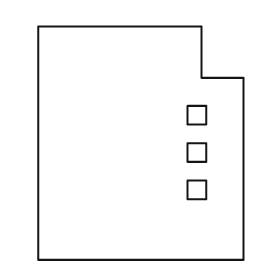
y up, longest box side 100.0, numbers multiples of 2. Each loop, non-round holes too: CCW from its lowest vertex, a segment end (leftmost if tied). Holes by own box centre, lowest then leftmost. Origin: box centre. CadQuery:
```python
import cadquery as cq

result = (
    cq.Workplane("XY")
    .moveTo(-44.0, -50.0)
    .lineTo(44.0, -50.0)
    .lineTo(44.0, 28.0)
    .lineTo(26.0, 28.0)
    .lineTo(26.0, 50.0)
    .lineTo(-44.0, 50.0)
    .close()
    .moveTo(20.0, -24.0)
    .lineTo(28.0, -24.0)
    .lineTo(28.0, -16.0)
    .lineTo(20.0, -16.0)
    .close()
    .moveTo(20.0, -8.0)
    .lineTo(28.0, -8.0)
    .lineTo(28.0, 0.0)
    .lineTo(20.0, 0.0)
    .close()
    .moveTo(20.0, 8.0)
    .lineTo(28.0, 8.0)
    .lineTo(28.0, 16.0)
    .lineTo(20.0, 16.0)
    .close()
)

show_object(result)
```